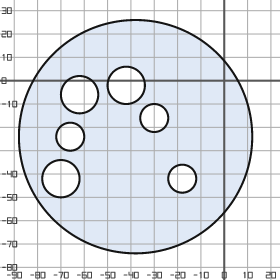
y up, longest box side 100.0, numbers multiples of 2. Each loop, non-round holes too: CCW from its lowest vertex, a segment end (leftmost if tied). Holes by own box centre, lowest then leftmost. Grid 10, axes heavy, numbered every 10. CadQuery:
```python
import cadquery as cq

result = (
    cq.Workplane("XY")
    .moveTo(-38.0, -24.0)
    .circle(50.0)
    .moveTo(-70.0, -42.0)
    .circle(8.0)
    .moveTo(-18.0, -42.0)
    .circle(6.0)
    .moveTo(-66.0, -24.0)
    .circle(6.0)
    .moveTo(-30.0, -16.0)
    .circle(6.0)
    .moveTo(-62.0, -6.0)
    .circle(8.0)
    .moveTo(-42.0, -2.0)
    .circle(8.0)
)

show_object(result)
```